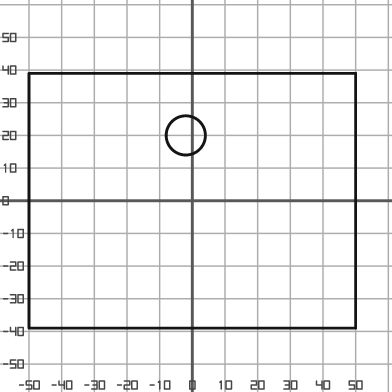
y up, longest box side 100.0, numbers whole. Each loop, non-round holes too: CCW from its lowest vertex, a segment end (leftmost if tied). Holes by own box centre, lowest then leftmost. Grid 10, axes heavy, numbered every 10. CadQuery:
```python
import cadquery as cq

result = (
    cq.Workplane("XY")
    .moveTo(-50.0, -39.0)
    .lineTo(50.0, -39.0)
    .lineTo(50.0, 39.0)
    .lineTo(-50.0, 39.0)
    .close()
    .moveTo(-2.0, 20.0)
    .circle(6.0)
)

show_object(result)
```